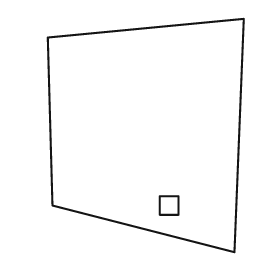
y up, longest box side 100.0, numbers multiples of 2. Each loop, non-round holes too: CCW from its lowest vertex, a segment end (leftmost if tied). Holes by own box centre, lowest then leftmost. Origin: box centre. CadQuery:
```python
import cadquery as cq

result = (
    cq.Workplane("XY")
    .moveTo(38.0, -50.0)
    .lineTo(42.0, 50.0)
    .lineTo(-42.0, 42.0)
    .lineTo(-40.0, -30.0)
    .close()
    .moveTo(6.0, -34.0)
    .lineTo(14.0, -34.0)
    .lineTo(14.0, -26.0)
    .lineTo(6.0, -26.0)
    .close()
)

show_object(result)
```